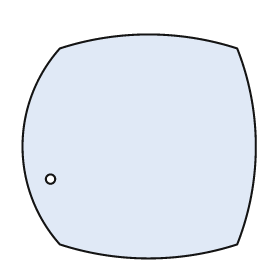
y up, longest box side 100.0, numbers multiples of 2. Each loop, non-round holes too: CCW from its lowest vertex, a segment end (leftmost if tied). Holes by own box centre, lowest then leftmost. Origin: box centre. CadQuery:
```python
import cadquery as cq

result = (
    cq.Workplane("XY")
    .moveTo(-34.0, -42.0)
    .threePointArc((4.0, -48.0), (42.0, -42.0))
    .threePointArc((50.0, 0.0), (42.0, 42.0))
    .threePointArc((4.0, 48.0), (-34.0, 42.0))
    .threePointArc((-50.0, 0.0), (-34.0, -42.0))
    .close()
    .moveTo(-38.0, -14.0)
    .circle(2.0)
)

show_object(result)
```